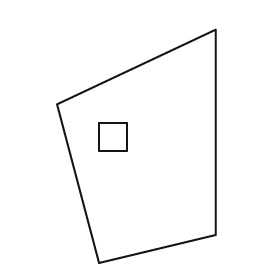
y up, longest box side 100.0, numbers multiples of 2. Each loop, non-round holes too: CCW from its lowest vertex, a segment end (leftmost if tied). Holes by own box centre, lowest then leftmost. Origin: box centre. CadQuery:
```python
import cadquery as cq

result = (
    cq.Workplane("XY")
    .moveTo(-16.0, -50.0)
    .lineTo(34.0, -38.0)
    .lineTo(34.0, 50.0)
    .lineTo(-34.0, 18.0)
    .close()
    .moveTo(-16.0, -2.0)
    .lineTo(-4.0, -2.0)
    .lineTo(-4.0, 10.0)
    .lineTo(-16.0, 10.0)
    .close()
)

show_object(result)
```